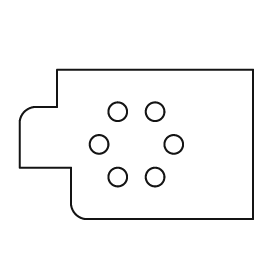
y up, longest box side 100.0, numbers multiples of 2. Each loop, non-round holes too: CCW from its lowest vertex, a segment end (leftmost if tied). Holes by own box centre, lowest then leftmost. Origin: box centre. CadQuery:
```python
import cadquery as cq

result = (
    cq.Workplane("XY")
    .moveTo(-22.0, -32.0)
    .lineTo(50.0, -32.0)
    .lineTo(50.0, 32.0)
    .lineTo(-34.0, 32.0)
    .lineTo(-34.0, 16.0)
    .lineTo(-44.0, 16.0)
    .threePointArc((-48.0, 14.0), (-50.0, 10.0))
    .lineTo(-50.0, -10.0)
    .lineTo(-28.0, -10.0)
    .lineTo(-28.0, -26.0)
    .threePointArc((-26.0, -30.0), (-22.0, -32.0))
    .close()
    .moveTo(-8.0, -14.0)
    .circle(4.0)
    .moveTo(8.0, -14.0)
    .circle(4.0)
    .moveTo(-16.0, 0.0)
    .circle(4.0)
    .moveTo(16.0, 0.0)
    .circle(4.0)
    .moveTo(-8.0, 14.0)
    .circle(4.0)
    .moveTo(8.0, 14.0)
    .circle(4.0)
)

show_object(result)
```